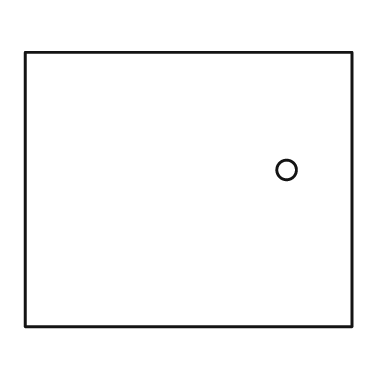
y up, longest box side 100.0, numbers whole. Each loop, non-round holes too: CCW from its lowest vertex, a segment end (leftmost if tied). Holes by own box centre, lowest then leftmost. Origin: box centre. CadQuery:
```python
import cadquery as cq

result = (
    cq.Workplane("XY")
    .moveTo(-50.0, -42.0)
    .lineTo(50.0, -42.0)
    .lineTo(50.0, 42.0)
    .lineTo(-50.0, 42.0)
    .close()
    .moveTo(30.0, 6.0)
    .circle(3.0)
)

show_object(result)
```